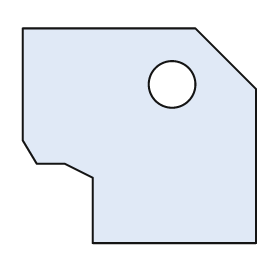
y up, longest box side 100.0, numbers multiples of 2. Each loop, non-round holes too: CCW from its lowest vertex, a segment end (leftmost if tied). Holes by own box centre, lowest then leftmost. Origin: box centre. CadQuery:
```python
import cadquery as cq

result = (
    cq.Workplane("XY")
    .moveTo(-20.0, -46.0)
    .lineTo(50.0, -46.0)
    .lineTo(50.0, 20.0)
    .lineTo(24.0, 46.0)
    .lineTo(-50.0, 46.0)
    .lineTo(-50.0, -2.0)
    .lineTo(-44.0, -12.0)
    .lineTo(-32.0, -12.0)
    .lineTo(-20.0, -18.0)
    .close()
    .moveTo(14.0, 22.0)
    .circle(10.0)
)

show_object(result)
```